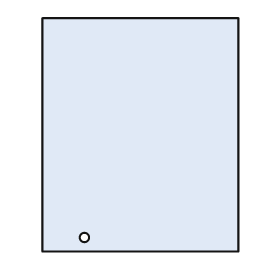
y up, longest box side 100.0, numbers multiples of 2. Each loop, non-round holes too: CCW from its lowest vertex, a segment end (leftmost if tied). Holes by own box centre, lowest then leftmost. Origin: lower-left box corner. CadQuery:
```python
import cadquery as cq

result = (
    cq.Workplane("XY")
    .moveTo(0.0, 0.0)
    .lineTo(84.0, 0.0)
    .lineTo(84.0, 100.0)
    .lineTo(0.0, 100.0)
    .close()
    .moveTo(18.0, 6.0)
    .circle(2.0)
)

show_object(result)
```